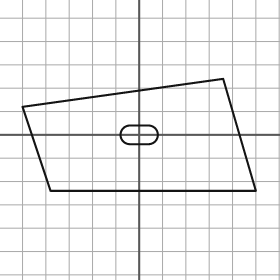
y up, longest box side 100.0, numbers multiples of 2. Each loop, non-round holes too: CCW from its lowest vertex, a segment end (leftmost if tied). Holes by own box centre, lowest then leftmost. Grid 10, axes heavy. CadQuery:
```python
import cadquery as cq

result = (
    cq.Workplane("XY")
    .moveTo(-38.0, -24.0)
    .lineTo(50.0, -24.0)
    .lineTo(36.0, 24.0)
    .lineTo(-50.0, 12.0)
    .close()
    .moveTo(-4.0, -4.0)
    .lineTo(4.0, -4.0)
    .threePointArc((8.0, 0.0), (4.0, 4.0))
    .lineTo(-4.0, 4.0)
    .threePointArc((-8.0, 0.0), (-4.0, -4.0))
    .close()
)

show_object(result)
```